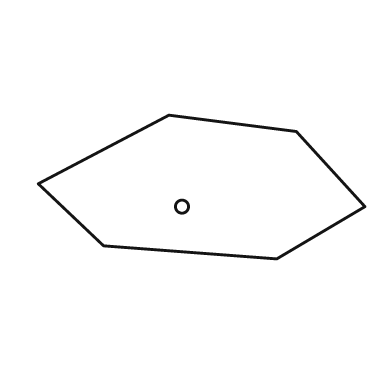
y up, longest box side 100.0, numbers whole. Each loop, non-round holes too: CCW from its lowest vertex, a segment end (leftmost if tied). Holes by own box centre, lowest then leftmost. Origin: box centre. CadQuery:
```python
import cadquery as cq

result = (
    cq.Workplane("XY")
    .moveTo(23.0, -22.0)
    .lineTo(50.0, -6.0)
    .lineTo(29.0, 17.0)
    .lineTo(-10.0, 22.0)
    .lineTo(-50.0, 1.0)
    .lineTo(-30.0, -18.0)
    .close()
    .moveTo(-6.0, -6.0)
    .circle(2.0)
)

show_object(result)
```